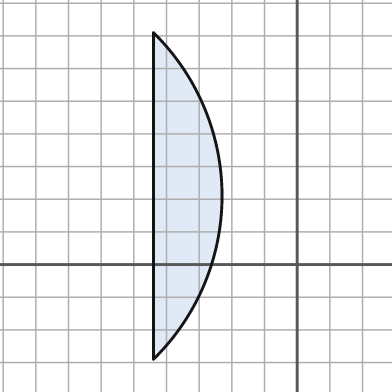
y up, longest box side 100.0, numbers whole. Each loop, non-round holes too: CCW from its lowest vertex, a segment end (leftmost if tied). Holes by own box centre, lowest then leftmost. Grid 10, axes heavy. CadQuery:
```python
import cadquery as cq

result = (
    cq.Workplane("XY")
    .moveTo(-44.0, -29.0)
    .threePointArc((-23.0, 21.0), (-44.0, 71.0))
    .close()
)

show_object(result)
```